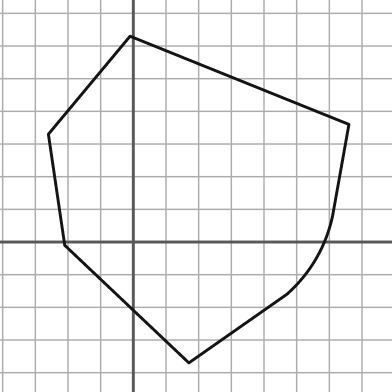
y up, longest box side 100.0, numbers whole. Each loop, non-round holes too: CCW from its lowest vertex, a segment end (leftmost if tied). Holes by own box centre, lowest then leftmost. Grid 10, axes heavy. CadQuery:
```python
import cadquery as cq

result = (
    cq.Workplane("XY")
    .moveTo(17.0, -37.0)
    .lineTo(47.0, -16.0)
    .threePointArc((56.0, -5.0), (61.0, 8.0))
    .lineTo(66.0, 36.0)
    .lineTo(-1.0, 63.0)
    .lineTo(-26.0, 33.0)
    .lineTo(-21.0, -1.0)
    .close()
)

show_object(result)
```